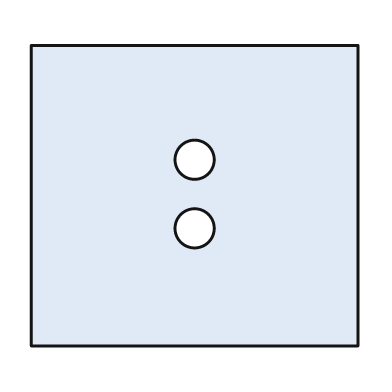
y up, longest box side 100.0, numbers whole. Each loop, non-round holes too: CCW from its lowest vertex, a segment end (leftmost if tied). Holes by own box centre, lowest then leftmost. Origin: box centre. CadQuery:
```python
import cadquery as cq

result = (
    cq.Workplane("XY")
    .moveTo(-50.0, -46.0)
    .lineTo(50.0, -46.0)
    .lineTo(50.0, 46.0)
    .lineTo(-50.0, 46.0)
    .close()
    .moveTo(0.0, -10.0)
    .circle(6.0)
    .moveTo(0.0, 11.0)
    .circle(6.0)
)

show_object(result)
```